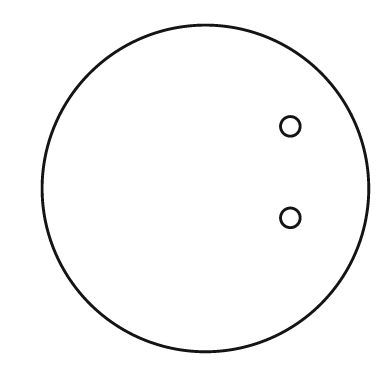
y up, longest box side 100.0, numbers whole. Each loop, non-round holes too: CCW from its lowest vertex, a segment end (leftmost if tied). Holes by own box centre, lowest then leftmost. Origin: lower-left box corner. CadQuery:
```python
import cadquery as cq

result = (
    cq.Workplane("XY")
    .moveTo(50.0, 50.0)
    .circle(50.0)
    .moveTo(76.0, 41.0)
    .circle(3.0)
    .moveTo(76.0, 69.0)
    .circle(3.0)
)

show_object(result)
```